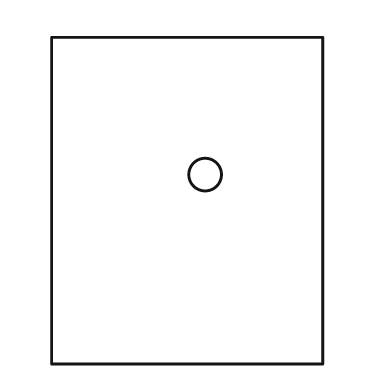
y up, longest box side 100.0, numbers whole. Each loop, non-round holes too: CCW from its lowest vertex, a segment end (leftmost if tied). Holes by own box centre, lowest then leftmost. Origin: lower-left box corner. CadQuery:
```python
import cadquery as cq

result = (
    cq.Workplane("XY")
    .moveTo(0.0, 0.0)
    .lineTo(83.0, 0.0)
    .lineTo(83.0, 100.0)
    .lineTo(0.0, 100.0)
    .close()
    .moveTo(47.0, 58.0)
    .circle(5.0)
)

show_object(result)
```